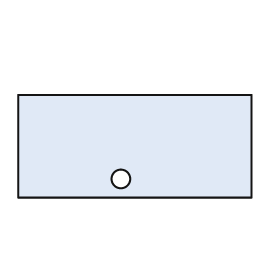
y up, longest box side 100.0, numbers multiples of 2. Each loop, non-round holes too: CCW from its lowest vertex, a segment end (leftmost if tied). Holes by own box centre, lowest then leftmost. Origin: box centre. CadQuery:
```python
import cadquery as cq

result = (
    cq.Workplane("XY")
    .moveTo(-50.0, -22.0)
    .lineTo(50.0, -22.0)
    .lineTo(50.0, 22.0)
    .lineTo(-50.0, 22.0)
    .close()
    .moveTo(-6.0, -14.0)
    .circle(4.0)
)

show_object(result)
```